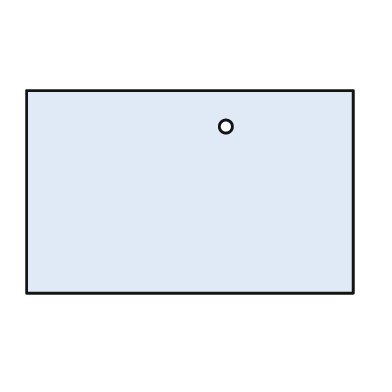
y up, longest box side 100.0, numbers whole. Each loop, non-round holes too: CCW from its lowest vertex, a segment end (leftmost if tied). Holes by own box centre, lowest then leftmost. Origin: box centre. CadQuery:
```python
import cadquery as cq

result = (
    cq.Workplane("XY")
    .moveTo(-50.0, -31.0)
    .lineTo(50.0, -31.0)
    .lineTo(50.0, 31.0)
    .lineTo(-50.0, 31.0)
    .close()
    .moveTo(11.0, 20.0)
    .circle(2.0)
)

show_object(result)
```